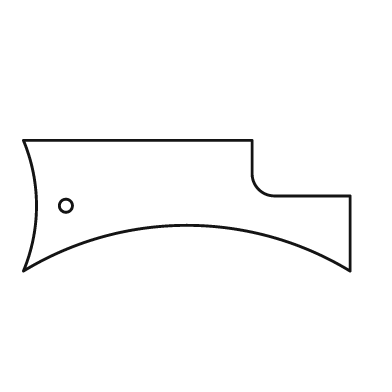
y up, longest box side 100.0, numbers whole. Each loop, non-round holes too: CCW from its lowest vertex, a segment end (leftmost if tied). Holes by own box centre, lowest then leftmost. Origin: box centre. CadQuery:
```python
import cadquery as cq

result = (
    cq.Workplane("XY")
    .moveTo(-50.0, -20.0)
    .threePointArc((0.0, -6.0), (50.0, -20.0))
    .lineTo(50.0, 3.0)
    .lineTo(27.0, 3.0)
    .threePointArc((22.0, 5.0), (20.0, 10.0))
    .lineTo(20.0, 20.0)
    .lineTo(-50.0, 20.0)
    .threePointArc((-46.0, 0.0), (-50.0, -20.0))
    .close()
    .moveTo(-37.0, 0.0)
    .circle(2.0)
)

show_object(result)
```